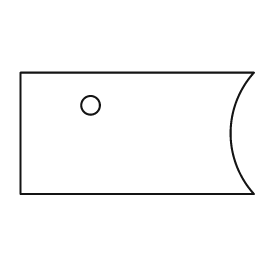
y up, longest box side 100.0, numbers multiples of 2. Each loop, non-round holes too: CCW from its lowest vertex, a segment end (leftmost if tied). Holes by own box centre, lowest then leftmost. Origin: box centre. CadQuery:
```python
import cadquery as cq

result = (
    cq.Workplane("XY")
    .moveTo(-50.0, -26.0)
    .lineTo(50.0, -26.0)
    .threePointArc((40.0, 0.0), (50.0, 26.0))
    .lineTo(-50.0, 26.0)
    .close()
    .moveTo(-20.0, 12.0)
    .circle(4.0)
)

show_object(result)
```